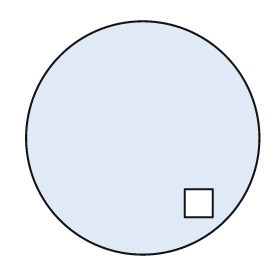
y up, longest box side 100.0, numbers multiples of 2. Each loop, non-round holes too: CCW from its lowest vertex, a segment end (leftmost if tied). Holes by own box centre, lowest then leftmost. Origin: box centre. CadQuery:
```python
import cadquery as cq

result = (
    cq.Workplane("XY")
    .moveTo(0.0, 0.0)
    .circle(50.0)
    .moveTo(18.0, -34.0)
    .lineTo(30.0, -34.0)
    .lineTo(30.0, -22.0)
    .lineTo(18.0, -22.0)
    .close()
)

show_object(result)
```